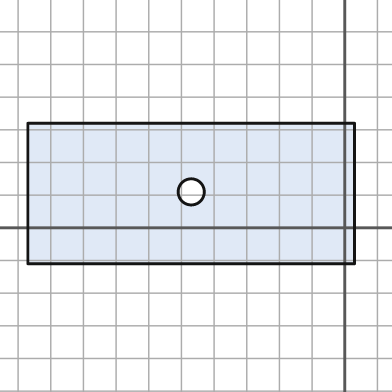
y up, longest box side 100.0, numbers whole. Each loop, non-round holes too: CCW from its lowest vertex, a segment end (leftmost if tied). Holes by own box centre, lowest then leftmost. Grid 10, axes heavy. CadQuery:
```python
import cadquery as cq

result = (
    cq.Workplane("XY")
    .moveTo(-97.0, -11.0)
    .lineTo(3.0, -11.0)
    .lineTo(3.0, 32.0)
    .lineTo(-97.0, 32.0)
    .close()
    .moveTo(-47.0, 11.0)
    .circle(4.0)
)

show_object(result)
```